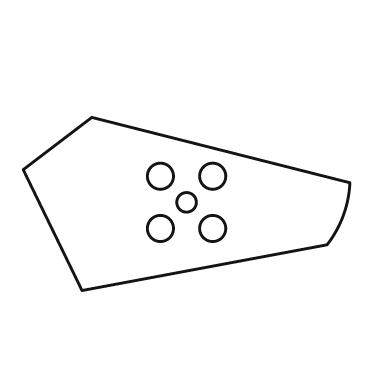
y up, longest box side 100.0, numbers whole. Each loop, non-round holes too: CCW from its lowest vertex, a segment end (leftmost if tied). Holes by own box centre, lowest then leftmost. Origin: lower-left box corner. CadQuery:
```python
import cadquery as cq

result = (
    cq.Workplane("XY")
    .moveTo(18.0, 0.0)
    .lineTo(93.0, 14.0)
    .threePointArc((98.0, 23.0), (100.0, 33.0))
    .lineTo(21.0, 53.0)
    .lineTo(0.0, 37.0)
    .close()
    .moveTo(42.0, 19.0)
    .circle(4.0)
    .moveTo(58.0, 19.0)
    .circle(4.0)
    .moveTo(50.0, 27.0)
    .circle(3.0)
    .moveTo(42.0, 35.0)
    .circle(4.0)
    .moveTo(58.0, 35.0)
    .circle(4.0)
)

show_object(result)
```